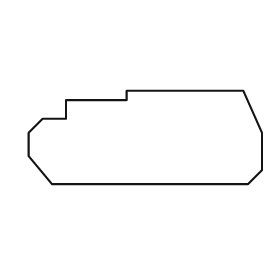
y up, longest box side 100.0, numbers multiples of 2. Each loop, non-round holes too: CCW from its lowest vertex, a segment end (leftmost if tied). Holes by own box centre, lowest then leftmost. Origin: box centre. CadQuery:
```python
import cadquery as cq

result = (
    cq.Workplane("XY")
    .moveTo(-40.0, -20.0)
    .lineTo(44.0, -20.0)
    .lineTo(50.0, -14.0)
    .lineTo(50.0, 2.0)
    .lineTo(42.0, 20.0)
    .lineTo(-8.0, 20.0)
    .lineTo(-8.0, 16.0)
    .lineTo(-34.0, 16.0)
    .lineTo(-34.0, 8.0)
    .lineTo(-44.0, 8.0)
    .lineTo(-50.0, 2.0)
    .lineTo(-50.0, -8.0)
    .close()
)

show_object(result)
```